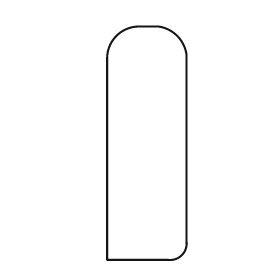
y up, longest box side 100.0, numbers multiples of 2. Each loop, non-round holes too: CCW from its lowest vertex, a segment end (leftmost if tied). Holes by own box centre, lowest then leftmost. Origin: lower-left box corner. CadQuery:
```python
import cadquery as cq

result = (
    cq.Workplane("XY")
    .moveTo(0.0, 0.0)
    .lineTo(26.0, 0.0)
    .threePointArc((32.0, 2.0), (34.0, 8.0))
    .lineTo(34.0, 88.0)
    .threePointArc((30.0, 96.0), (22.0, 100.0))
    .lineTo(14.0, 100.0)
    .threePointArc((4.0, 96.0), (0.0, 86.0))
    .close()
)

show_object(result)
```